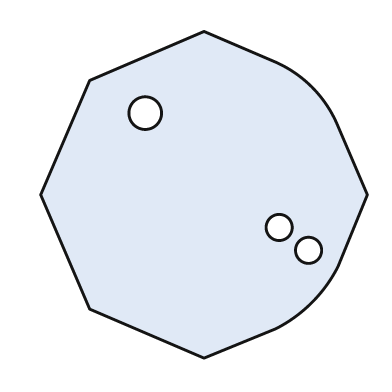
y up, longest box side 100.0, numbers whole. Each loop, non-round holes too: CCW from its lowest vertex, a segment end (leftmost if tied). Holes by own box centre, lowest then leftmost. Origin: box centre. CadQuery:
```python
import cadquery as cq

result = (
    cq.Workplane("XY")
    .moveTo(0.0, -50.0)
    .lineTo(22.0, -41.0)
    .threePointArc((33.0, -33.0), (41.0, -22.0))
    .lineTo(50.0, 0.0)
    .lineTo(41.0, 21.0)
    .threePointArc((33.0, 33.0), (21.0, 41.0))
    .lineTo(0.0, 50.0)
    .lineTo(-35.0, 35.0)
    .lineTo(-50.0, 0.0)
    .lineTo(-35.0, -35.0)
    .close()
    .moveTo(32.0, -17.0)
    .circle(4.0)
    .moveTo(23.0, -10.0)
    .circle(4.0)
    .moveTo(-18.0, 25.0)
    .circle(5.0)
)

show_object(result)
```